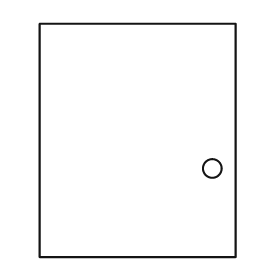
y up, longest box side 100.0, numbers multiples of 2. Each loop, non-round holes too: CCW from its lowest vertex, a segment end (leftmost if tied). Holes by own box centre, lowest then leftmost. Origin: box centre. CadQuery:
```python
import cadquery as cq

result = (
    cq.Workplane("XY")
    .moveTo(-42.0, -50.0)
    .lineTo(42.0, -50.0)
    .lineTo(42.0, 50.0)
    .lineTo(-42.0, 50.0)
    .close()
    .moveTo(32.0, -12.0)
    .circle(4.0)
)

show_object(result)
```